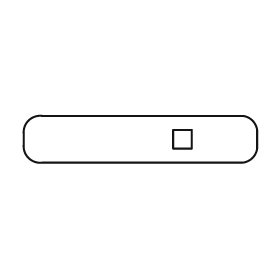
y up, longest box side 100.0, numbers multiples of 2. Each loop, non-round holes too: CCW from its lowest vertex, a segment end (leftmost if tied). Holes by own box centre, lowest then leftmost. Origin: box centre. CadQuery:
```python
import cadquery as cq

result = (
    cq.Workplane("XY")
    .moveTo(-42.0, -10.0)
    .lineTo(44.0, -10.0)
    .threePointArc((48.0, -8.0), (50.0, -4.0))
    .lineTo(50.0, 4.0)
    .threePointArc((48.0, 8.0), (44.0, 10.0))
    .lineTo(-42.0, 10.0)
    .threePointArc((-48.0, 8.0), (-50.0, 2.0))
    .lineTo(-50.0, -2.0)
    .threePointArc((-48.0, -8.0), (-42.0, -10.0))
    .close()
    .moveTo(14.0, -4.0)
    .lineTo(22.0, -4.0)
    .lineTo(22.0, 4.0)
    .lineTo(14.0, 4.0)
    .close()
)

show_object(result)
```